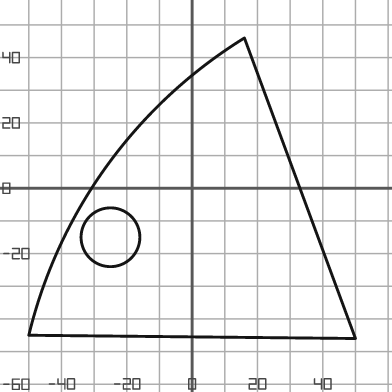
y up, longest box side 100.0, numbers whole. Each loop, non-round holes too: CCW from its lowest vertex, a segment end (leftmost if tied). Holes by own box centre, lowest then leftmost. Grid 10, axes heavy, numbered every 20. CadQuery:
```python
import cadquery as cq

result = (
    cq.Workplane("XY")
    .moveTo(50.0, -46.0)
    .lineTo(16.0, 46.0)
    .threePointArc((-26.0, 7.0), (-50.0, -45.0))
    .close()
    .moveTo(-25.0, -15.0)
    .circle(9.0)
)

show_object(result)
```